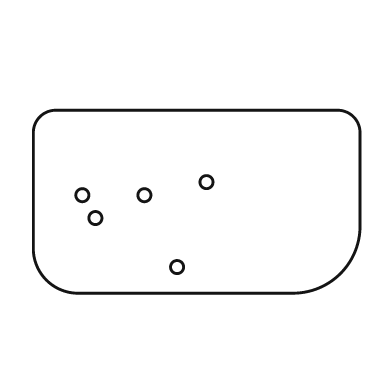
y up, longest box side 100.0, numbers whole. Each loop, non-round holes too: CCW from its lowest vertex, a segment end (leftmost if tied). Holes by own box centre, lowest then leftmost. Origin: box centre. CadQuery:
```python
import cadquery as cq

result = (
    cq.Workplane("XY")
    .moveTo(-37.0, -28.0)
    .lineTo(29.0, -28.0)
    .threePointArc((44.0, -22.0), (50.0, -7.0))
    .lineTo(50.0, 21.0)
    .threePointArc((48.0, 26.0), (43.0, 28.0))
    .lineTo(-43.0, 28.0)
    .threePointArc((-48.0, 26.0), (-50.0, 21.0))
    .lineTo(-50.0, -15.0)
    .threePointArc((-46.0, -24.0), (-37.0, -28.0))
    .close()
    .moveTo(-6.0, -20.0)
    .circle(2.0)
    .moveTo(-31.0, -5.0)
    .circle(2.0)
    .moveTo(-35.0, 2.0)
    .circle(2.0)
    .moveTo(-16.0, 2.0)
    .circle(2.0)
    .moveTo(3.0, 6.0)
    .circle(2.0)
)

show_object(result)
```